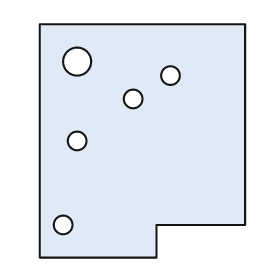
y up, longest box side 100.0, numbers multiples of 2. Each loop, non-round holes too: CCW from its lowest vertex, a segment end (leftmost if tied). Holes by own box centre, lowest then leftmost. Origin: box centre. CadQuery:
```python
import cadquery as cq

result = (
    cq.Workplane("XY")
    .moveTo(-44.0, -50.0)
    .lineTo(6.0, -50.0)
    .lineTo(6.0, -36.0)
    .lineTo(44.0, -36.0)
    .lineTo(44.0, 50.0)
    .lineTo(-44.0, 50.0)
    .close()
    .moveTo(-34.0, -36.0)
    .circle(4.0)
    .moveTo(-28.0, 0.0)
    .circle(4.0)
    .moveTo(-4.0, 18.0)
    .circle(4.0)
    .moveTo(12.0, 28.0)
    .circle(4.0)
    .moveTo(-28.0, 34.0)
    .circle(6.0)
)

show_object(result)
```